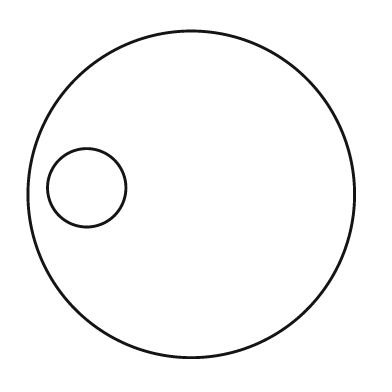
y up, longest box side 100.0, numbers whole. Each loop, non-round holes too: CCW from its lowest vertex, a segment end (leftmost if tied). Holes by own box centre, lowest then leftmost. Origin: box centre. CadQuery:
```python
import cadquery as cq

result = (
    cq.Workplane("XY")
    .moveTo(0.0, 0.0)
    .circle(50.0)
    .moveTo(-32.0, 2.0)
    .circle(12.0)
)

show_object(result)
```